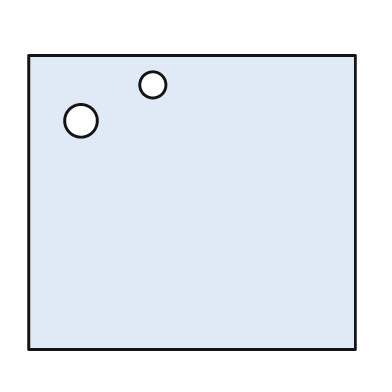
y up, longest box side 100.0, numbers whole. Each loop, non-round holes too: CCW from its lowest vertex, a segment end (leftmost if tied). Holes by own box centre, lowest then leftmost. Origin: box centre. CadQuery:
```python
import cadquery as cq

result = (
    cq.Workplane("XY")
    .moveTo(-50.0, -45.0)
    .lineTo(50.0, -45.0)
    .lineTo(50.0, 45.0)
    .lineTo(-50.0, 45.0)
    .close()
    .moveTo(-34.0, 25.0)
    .circle(5.0)
    .moveTo(-12.0, 36.0)
    .circle(4.0)
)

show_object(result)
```